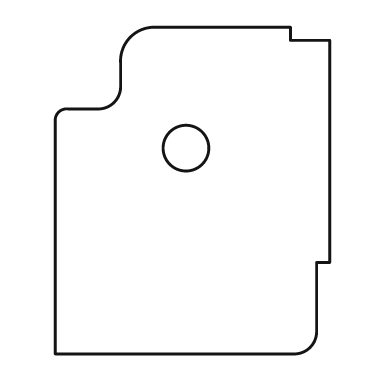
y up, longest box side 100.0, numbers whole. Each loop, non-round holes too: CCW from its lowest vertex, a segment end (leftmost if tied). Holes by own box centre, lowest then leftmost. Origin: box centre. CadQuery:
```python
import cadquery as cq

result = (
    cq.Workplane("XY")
    .moveTo(-42.0, -50.0)
    .lineTo(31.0, -50.0)
    .threePointArc((36.0, -48.0), (38.0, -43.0))
    .lineTo(38.0, -22.0)
    .lineTo(42.0, -22.0)
    .lineTo(42.0, 46.0)
    .lineTo(30.0, 46.0)
    .lineTo(30.0, 50.0)
    .lineTo(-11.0, 50.0)
    .threePointArc((-19.0, 47.0), (-22.0, 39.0))
    .lineTo(-22.0, 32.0)
    .threePointArc((-24.0, 27.0), (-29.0, 25.0))
    .lineTo(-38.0, 25.0)
    .threePointArc((-41.0, 24.0), (-42.0, 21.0))
    .close()
    .moveTo(-2.0, 13.0)
    .circle(7.0)
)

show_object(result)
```